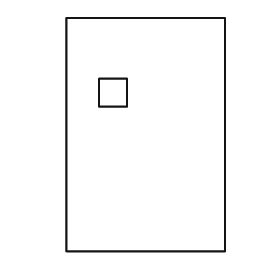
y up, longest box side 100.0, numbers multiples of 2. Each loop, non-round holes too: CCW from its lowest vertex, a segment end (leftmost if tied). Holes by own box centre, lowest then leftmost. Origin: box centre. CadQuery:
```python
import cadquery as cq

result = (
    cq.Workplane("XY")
    .moveTo(-34.0, -50.0)
    .lineTo(34.0, -50.0)
    .lineTo(34.0, 50.0)
    .lineTo(-34.0, 50.0)
    .close()
    .moveTo(-20.0, 12.0)
    .lineTo(-8.0, 12.0)
    .lineTo(-8.0, 24.0)
    .lineTo(-20.0, 24.0)
    .close()
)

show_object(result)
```